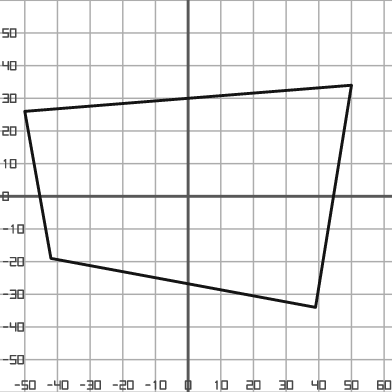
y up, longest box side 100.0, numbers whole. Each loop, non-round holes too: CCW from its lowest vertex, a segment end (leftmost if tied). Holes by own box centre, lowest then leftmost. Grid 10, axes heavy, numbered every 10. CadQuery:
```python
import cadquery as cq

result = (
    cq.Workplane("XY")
    .moveTo(39.0, -34.0)
    .lineTo(50.0, 34.0)
    .lineTo(-50.0, 26.0)
    .lineTo(-42.0, -19.0)
    .close()
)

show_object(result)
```